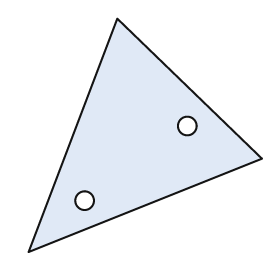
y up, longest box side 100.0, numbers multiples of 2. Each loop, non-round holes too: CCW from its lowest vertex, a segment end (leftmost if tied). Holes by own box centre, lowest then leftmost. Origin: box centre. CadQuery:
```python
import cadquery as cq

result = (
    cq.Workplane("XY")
    .moveTo(-50.0, -50.0)
    .lineTo(50.0, -10.0)
    .lineTo(-12.0, 50.0)
    .close()
    .moveTo(-26.0, -28.0)
    .circle(4.0)
    .moveTo(18.0, 4.0)
    .circle(4.0)
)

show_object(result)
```